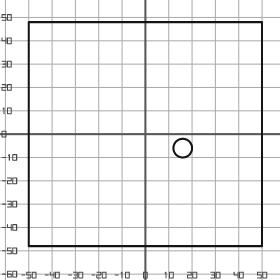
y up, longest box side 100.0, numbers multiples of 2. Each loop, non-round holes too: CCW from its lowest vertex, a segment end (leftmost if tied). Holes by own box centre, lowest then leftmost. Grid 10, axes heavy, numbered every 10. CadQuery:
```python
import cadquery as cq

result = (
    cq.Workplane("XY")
    .moveTo(-50.0, -48.0)
    .lineTo(50.0, -48.0)
    .lineTo(50.0, 48.0)
    .lineTo(-50.0, 48.0)
    .close()
    .moveTo(16.0, -6.0)
    .circle(4.0)
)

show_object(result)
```